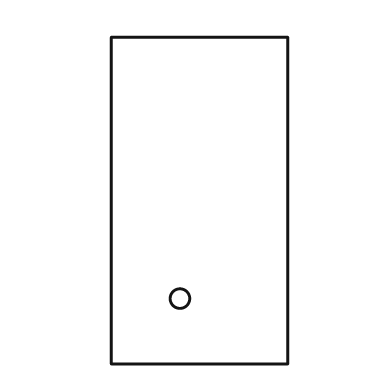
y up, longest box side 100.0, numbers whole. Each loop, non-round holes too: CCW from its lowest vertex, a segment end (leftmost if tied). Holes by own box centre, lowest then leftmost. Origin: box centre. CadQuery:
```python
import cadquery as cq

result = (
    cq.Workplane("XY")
    .moveTo(-27.0, -50.0)
    .lineTo(27.0, -50.0)
    .lineTo(27.0, 50.0)
    .lineTo(-27.0, 50.0)
    .close()
    .moveTo(-6.0, -30.0)
    .circle(3.0)
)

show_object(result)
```